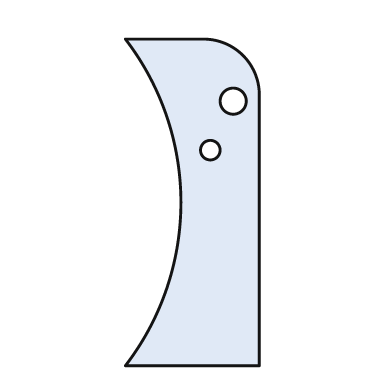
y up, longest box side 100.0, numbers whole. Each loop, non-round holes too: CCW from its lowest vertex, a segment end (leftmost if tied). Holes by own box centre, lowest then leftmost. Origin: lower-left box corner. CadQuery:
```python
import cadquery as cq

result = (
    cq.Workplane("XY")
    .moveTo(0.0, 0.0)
    .lineTo(41.0, 0.0)
    .lineTo(41.0, 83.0)
    .threePointArc((36.0, 95.0), (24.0, 100.0))
    .lineTo(0.0, 100.0)
    .threePointArc((17.0, 50.0), (0.0, 0.0))
    .close()
    .moveTo(26.0, 66.0)
    .circle(3.0)
    .moveTo(33.0, 81.0)
    .circle(4.0)
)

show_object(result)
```